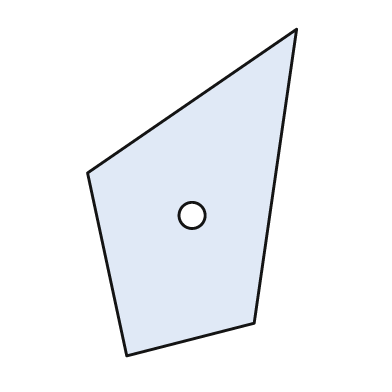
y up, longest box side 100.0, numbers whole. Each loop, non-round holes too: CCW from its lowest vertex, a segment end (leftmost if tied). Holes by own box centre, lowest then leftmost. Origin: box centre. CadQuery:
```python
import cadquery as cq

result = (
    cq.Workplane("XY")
    .moveTo(-20.0, -50.0)
    .lineTo(19.0, -40.0)
    .lineTo(32.0, 50.0)
    .lineTo(-32.0, 6.0)
    .close()
    .moveTo(0.0, -7.0)
    .circle(4.0)
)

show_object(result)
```